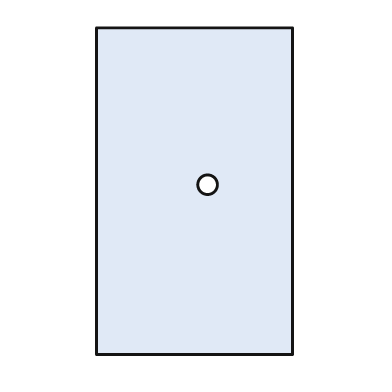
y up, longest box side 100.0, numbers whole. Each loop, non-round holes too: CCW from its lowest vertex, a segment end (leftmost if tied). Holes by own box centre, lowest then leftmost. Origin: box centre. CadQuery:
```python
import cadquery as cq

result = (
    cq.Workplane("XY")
    .moveTo(-30.0, -50.0)
    .lineTo(30.0, -50.0)
    .lineTo(30.0, 50.0)
    .lineTo(-30.0, 50.0)
    .close()
    .moveTo(4.0, 2.0)
    .circle(3.0)
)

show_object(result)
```